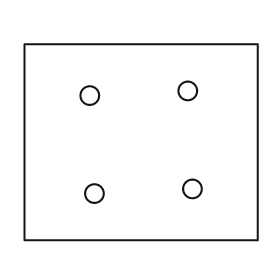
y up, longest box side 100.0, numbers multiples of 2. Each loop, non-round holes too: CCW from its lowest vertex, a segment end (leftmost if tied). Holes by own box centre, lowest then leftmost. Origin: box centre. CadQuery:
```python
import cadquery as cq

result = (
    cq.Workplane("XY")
    .moveTo(-50.0, -42.0)
    .lineTo(50.0, -42.0)
    .lineTo(50.0, 42.0)
    .lineTo(-50.0, 42.0)
    .close()
    .moveTo(-20.0, -22.0)
    .circle(4.0)
    .moveTo(22.0, -20.0)
    .circle(4.0)
    .moveTo(-22.0, 20.0)
    .circle(4.0)
    .moveTo(20.0, 22.0)
    .circle(4.0)
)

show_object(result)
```